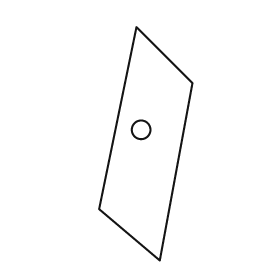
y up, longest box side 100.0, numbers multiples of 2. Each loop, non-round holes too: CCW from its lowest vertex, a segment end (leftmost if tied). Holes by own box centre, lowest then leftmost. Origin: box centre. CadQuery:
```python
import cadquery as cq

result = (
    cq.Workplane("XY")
    .moveTo(6.0, -50.0)
    .lineTo(20.0, 26.0)
    .lineTo(-4.0, 50.0)
    .lineTo(-20.0, -28.0)
    .close()
    .moveTo(-2.0, 6.0)
    .circle(4.0)
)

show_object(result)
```